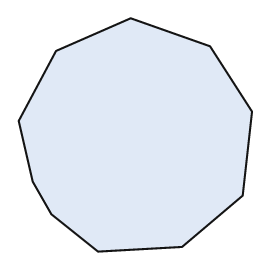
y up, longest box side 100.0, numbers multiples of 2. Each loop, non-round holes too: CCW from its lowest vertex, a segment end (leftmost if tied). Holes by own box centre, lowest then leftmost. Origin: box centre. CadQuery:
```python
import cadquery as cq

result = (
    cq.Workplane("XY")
    .moveTo(-16.0, -50.0)
    .lineTo(20.0, -48.0)
    .lineTo(46.0, -26.0)
    .lineTo(50.0, 10.0)
    .lineTo(32.0, 38.0)
    .lineTo(-2.0, 50.0)
    .lineTo(-34.0, 36.0)
    .lineTo(-50.0, 6.0)
    .lineTo(-44.0, -20.0)
    .lineTo(-36.0, -34.0)
    .close()
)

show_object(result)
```